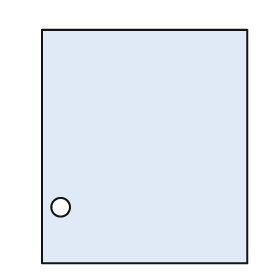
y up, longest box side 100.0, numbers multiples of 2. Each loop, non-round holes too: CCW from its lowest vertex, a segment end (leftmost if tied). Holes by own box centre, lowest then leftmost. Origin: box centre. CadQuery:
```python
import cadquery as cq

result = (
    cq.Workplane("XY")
    .moveTo(-44.0, -50.0)
    .lineTo(44.0, -50.0)
    .lineTo(44.0, 50.0)
    .lineTo(-44.0, 50.0)
    .close()
    .moveTo(-36.0, -26.0)
    .circle(4.0)
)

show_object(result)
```